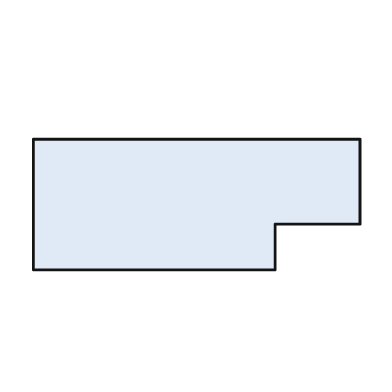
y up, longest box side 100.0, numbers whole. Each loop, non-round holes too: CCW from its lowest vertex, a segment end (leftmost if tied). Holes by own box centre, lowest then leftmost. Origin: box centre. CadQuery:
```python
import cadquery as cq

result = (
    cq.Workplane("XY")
    .moveTo(-50.0, -20.0)
    .lineTo(24.0, -20.0)
    .lineTo(24.0, -6.0)
    .lineTo(50.0, -6.0)
    .lineTo(50.0, 20.0)
    .lineTo(-50.0, 20.0)
    .close()
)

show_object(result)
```